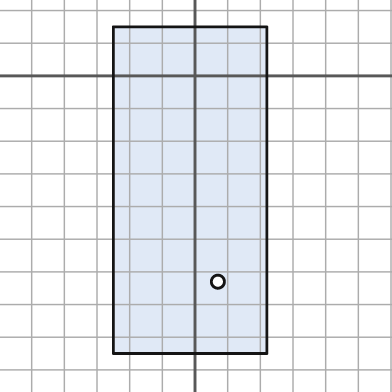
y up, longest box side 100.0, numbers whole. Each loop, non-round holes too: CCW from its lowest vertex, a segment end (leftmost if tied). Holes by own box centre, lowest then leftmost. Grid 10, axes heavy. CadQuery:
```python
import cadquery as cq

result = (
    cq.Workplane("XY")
    .moveTo(-25.0, -85.0)
    .lineTo(22.0, -85.0)
    .lineTo(22.0, 15.0)
    .lineTo(-25.0, 15.0)
    .close()
    .moveTo(7.0, -63.0)
    .circle(2.0)
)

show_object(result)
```